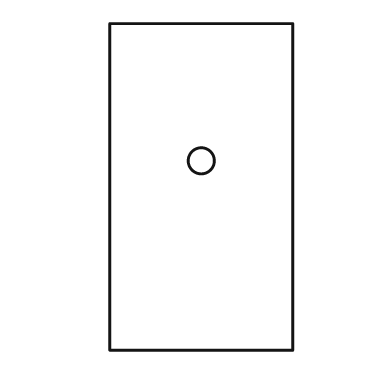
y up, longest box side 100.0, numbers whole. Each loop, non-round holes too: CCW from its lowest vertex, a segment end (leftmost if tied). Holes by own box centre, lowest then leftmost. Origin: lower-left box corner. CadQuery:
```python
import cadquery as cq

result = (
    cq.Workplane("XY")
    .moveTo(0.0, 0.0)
    .lineTo(56.0, 0.0)
    .lineTo(56.0, 100.0)
    .lineTo(0.0, 100.0)
    .close()
    .moveTo(28.0, 58.0)
    .circle(4.0)
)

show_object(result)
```